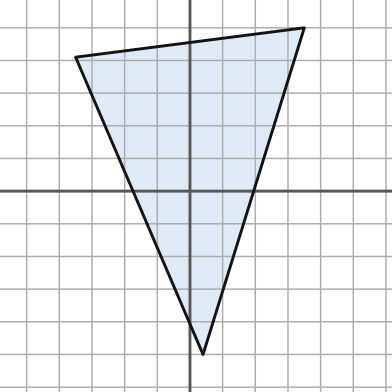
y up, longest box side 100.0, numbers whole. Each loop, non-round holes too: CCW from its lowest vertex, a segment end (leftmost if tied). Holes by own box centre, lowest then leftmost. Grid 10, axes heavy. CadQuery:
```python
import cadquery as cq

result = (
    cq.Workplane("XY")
    .moveTo(4.0, -50.0)
    .lineTo(35.0, 50.0)
    .lineTo(-35.0, 41.0)
    .close()
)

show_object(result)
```